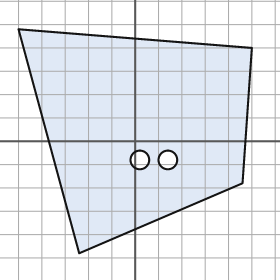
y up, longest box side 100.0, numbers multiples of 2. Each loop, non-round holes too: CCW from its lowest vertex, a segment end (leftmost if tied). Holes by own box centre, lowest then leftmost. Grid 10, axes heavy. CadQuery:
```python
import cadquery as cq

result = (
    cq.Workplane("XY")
    .moveTo(-24.0, -48.0)
    .lineTo(46.0, -18.0)
    .lineTo(50.0, 40.0)
    .lineTo(-50.0, 48.0)
    .close()
    .moveTo(2.0, -8.0)
    .circle(4.0)
    .moveTo(14.0, -8.0)
    .circle(4.0)
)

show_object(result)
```